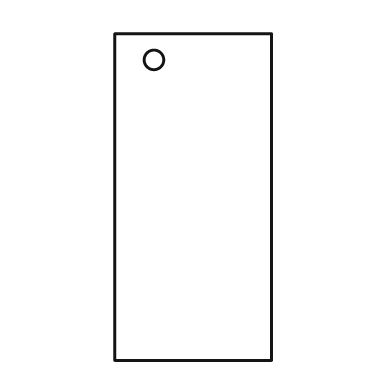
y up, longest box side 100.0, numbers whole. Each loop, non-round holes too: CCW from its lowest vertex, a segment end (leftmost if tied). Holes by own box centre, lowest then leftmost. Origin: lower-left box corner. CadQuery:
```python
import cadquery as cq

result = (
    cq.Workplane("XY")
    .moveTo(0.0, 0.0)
    .lineTo(48.0, 0.0)
    .lineTo(48.0, 100.0)
    .lineTo(0.0, 100.0)
    .close()
    .moveTo(12.0, 92.0)
    .circle(3.0)
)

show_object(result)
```